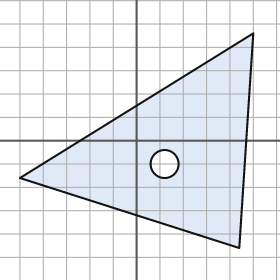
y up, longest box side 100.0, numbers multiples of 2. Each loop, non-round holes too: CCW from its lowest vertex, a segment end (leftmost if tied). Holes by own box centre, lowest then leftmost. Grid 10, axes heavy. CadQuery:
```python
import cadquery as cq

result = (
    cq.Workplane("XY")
    .moveTo(44.0, -46.0)
    .lineTo(50.0, 46.0)
    .lineTo(-50.0, -16.0)
    .close()
    .moveTo(12.0, -10.0)
    .circle(6.0)
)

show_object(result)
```